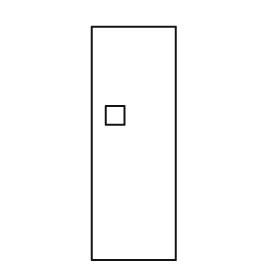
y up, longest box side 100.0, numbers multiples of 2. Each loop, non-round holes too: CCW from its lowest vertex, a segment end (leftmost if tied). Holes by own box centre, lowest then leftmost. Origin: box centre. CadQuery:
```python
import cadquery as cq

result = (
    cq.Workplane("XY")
    .moveTo(-18.0, -50.0)
    .lineTo(18.0, -50.0)
    .lineTo(18.0, 50.0)
    .lineTo(-18.0, 50.0)
    .close()
    .moveTo(-12.0, 8.0)
    .lineTo(-4.0, 8.0)
    .lineTo(-4.0, 16.0)
    .lineTo(-12.0, 16.0)
    .close()
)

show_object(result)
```